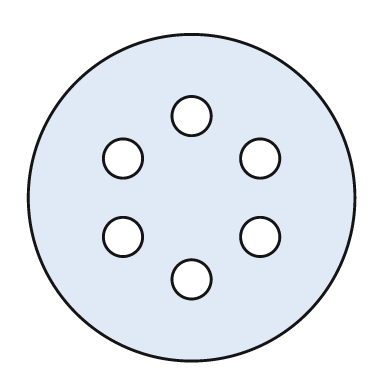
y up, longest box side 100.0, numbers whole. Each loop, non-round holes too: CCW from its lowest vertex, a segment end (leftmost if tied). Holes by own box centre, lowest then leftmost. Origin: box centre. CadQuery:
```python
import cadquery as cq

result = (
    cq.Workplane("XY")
    .moveTo(0.0, 0.0)
    .circle(50.0)
    .moveTo(0.0, -25.0)
    .circle(6.0)
    .moveTo(-21.0, -12.0)
    .circle(6.0)
    .moveTo(21.0, -12.0)
    .circle(6.0)
    .moveTo(-21.0, 12.0)
    .circle(6.0)
    .moveTo(21.0, 12.0)
    .circle(6.0)
    .moveTo(0.0, 25.0)
    .circle(6.0)
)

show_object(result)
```